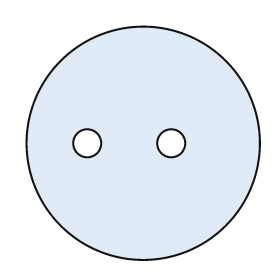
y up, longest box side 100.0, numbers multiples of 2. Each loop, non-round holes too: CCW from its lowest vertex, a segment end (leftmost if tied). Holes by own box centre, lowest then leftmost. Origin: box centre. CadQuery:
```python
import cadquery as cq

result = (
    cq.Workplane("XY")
    .moveTo(0.0, 0.0)
    .circle(50.0)
    .moveTo(-24.0, 0.0)
    .circle(6.0)
    .moveTo(12.0, 0.0)
    .circle(6.0)
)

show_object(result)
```